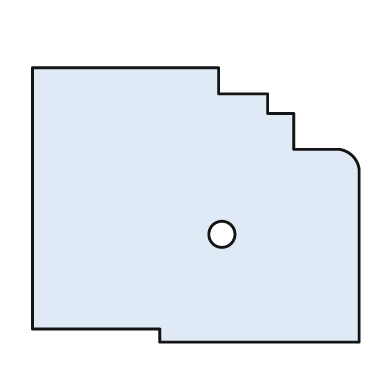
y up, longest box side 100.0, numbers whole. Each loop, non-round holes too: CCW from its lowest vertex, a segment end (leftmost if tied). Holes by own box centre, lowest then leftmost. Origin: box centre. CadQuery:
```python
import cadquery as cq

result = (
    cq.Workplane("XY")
    .moveTo(-11.0, -42.0)
    .lineTo(50.0, -42.0)
    .lineTo(50.0, 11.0)
    .threePointArc((48.0, 15.0), (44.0, 17.0))
    .lineTo(30.0, 17.0)
    .lineTo(30.0, 28.0)
    .lineTo(22.0, 28.0)
    .lineTo(22.0, 34.0)
    .lineTo(7.0, 34.0)
    .lineTo(7.0, 42.0)
    .lineTo(-50.0, 42.0)
    .lineTo(-50.0, -38.0)
    .lineTo(-11.0, -38.0)
    .close()
    .moveTo(8.0, -9.0)
    .circle(4.0)
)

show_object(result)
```